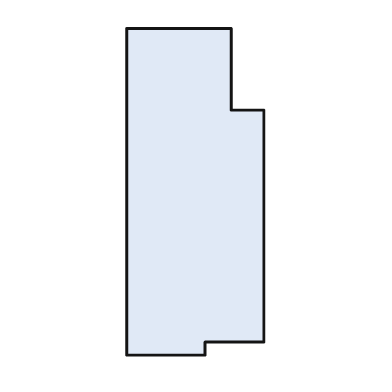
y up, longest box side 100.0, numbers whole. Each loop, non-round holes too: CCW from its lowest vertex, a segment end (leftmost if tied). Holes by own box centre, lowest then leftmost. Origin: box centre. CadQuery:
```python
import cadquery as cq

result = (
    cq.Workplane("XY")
    .moveTo(-21.0, -50.0)
    .lineTo(3.0, -50.0)
    .lineTo(3.0, -46.0)
    .lineTo(21.0, -46.0)
    .lineTo(21.0, 25.0)
    .lineTo(11.0, 25.0)
    .lineTo(11.0, 50.0)
    .lineTo(-21.0, 50.0)
    .close()
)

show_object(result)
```